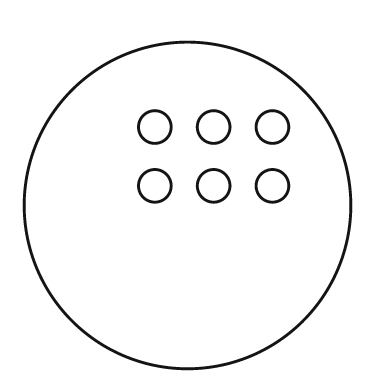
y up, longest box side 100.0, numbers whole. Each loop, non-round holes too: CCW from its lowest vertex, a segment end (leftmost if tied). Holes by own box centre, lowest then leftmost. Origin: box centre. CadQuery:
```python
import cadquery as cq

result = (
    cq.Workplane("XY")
    .moveTo(0.0, 0.0)
    .circle(50.0)
    .moveTo(-10.0, 6.0)
    .circle(5.0)
    .moveTo(8.0, 6.0)
    .circle(5.0)
    .moveTo(26.0, 6.0)
    .circle(5.0)
    .moveTo(-10.0, 24.0)
    .circle(5.0)
    .moveTo(8.0, 24.0)
    .circle(5.0)
    .moveTo(26.0, 24.0)
    .circle(5.0)
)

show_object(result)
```